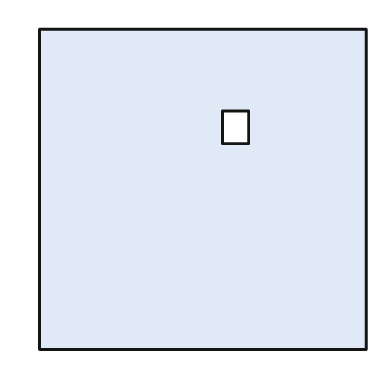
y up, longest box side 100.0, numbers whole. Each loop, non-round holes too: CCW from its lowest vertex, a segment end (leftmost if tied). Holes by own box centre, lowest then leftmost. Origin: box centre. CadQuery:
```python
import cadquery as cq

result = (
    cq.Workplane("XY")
    .moveTo(-50.0, -49.0)
    .lineTo(50.0, -49.0)
    .lineTo(50.0, 49.0)
    .lineTo(-50.0, 49.0)
    .close()
    .moveTo(6.0, 14.0)
    .lineTo(14.0, 14.0)
    .lineTo(14.0, 24.0)
    .lineTo(6.0, 24.0)
    .close()
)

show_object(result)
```